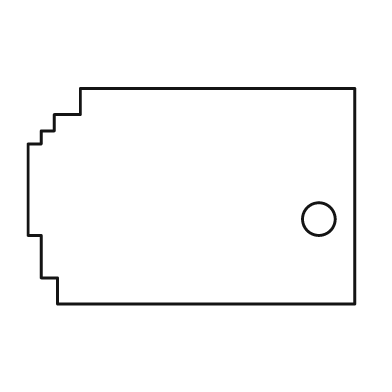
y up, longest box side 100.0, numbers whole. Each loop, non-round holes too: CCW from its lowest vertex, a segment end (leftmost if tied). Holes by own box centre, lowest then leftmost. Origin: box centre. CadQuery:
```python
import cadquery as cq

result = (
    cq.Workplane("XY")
    .moveTo(-41.0, -33.0)
    .lineTo(50.0, -33.0)
    .lineTo(50.0, 33.0)
    .lineTo(-34.0, 33.0)
    .lineTo(-34.0, 25.0)
    .lineTo(-42.0, 25.0)
    .lineTo(-42.0, 20.0)
    .lineTo(-46.0, 20.0)
    .lineTo(-46.0, 16.0)
    .lineTo(-50.0, 16.0)
    .lineTo(-50.0, -12.0)
    .lineTo(-46.0, -12.0)
    .lineTo(-46.0, -25.0)
    .lineTo(-41.0, -25.0)
    .close()
    .moveTo(39.0, -7.0)
    .circle(5.0)
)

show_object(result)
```